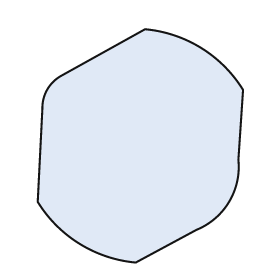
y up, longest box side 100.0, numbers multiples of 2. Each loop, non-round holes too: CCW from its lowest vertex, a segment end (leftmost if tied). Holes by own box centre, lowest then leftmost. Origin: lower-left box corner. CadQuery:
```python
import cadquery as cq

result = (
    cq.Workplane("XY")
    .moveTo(42.0, 0.0)
    .lineTo(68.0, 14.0)
    .threePointArc((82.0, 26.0), (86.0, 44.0))
    .lineTo(88.0, 74.0)
    .threePointArc((70.0, 92.0), (46.0, 100.0))
    .lineTo(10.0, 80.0)
    .threePointArc((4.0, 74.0), (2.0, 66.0))
    .lineTo(0.0, 26.0)
    .threePointArc((18.0, 8.0), (42.0, 0.0))
    .close()
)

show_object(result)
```